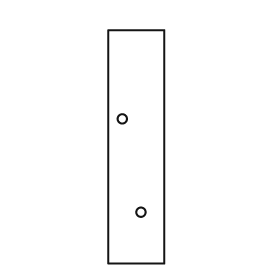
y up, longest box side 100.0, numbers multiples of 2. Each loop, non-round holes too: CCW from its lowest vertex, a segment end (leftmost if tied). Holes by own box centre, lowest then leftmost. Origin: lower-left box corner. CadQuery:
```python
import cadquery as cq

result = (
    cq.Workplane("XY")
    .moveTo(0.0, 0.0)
    .lineTo(24.0, 0.0)
    .lineTo(24.0, 100.0)
    .lineTo(0.0, 100.0)
    .close()
    .moveTo(14.0, 22.0)
    .circle(2.0)
    .moveTo(6.0, 62.0)
    .circle(2.0)
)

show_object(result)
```